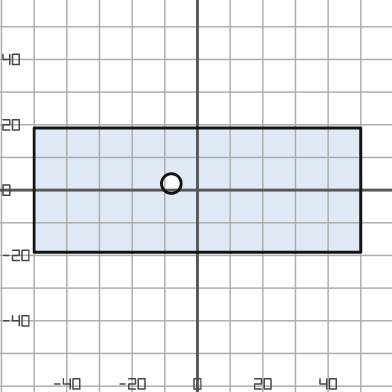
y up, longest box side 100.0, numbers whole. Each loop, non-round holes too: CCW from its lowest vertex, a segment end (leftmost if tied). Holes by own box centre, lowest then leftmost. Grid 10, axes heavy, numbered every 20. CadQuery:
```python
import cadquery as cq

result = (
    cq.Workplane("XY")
    .moveTo(-50.0, -19.0)
    .lineTo(50.0, -19.0)
    .lineTo(50.0, 19.0)
    .lineTo(-50.0, 19.0)
    .close()
    .moveTo(-8.0, 2.0)
    .circle(3.0)
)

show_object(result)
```